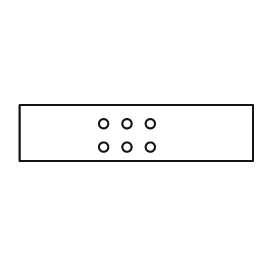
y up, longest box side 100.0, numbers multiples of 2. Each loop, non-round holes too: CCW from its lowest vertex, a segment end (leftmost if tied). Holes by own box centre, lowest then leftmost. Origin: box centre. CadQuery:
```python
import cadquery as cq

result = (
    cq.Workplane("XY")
    .moveTo(-50.0, -12.0)
    .lineTo(50.0, -12.0)
    .lineTo(50.0, 12.0)
    .lineTo(-50.0, 12.0)
    .close()
    .moveTo(-14.0, -6.0)
    .circle(2.0)
    .moveTo(-4.0, -6.0)
    .circle(2.0)
    .moveTo(6.0, -6.0)
    .circle(2.0)
    .moveTo(-14.0, 4.0)
    .circle(2.0)
    .moveTo(-4.0, 4.0)
    .circle(2.0)
    .moveTo(6.0, 4.0)
    .circle(2.0)
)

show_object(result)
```